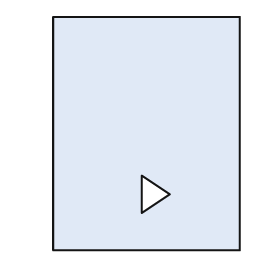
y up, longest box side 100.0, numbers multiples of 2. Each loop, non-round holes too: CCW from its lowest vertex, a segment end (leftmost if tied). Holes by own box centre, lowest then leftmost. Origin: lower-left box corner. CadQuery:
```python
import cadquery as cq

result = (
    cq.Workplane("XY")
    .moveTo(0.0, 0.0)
    .lineTo(80.0, 0.0)
    .lineTo(80.0, 100.0)
    .lineTo(0.0, 100.0)
    .close()
    .moveTo(38.0, 16.0)
    .lineTo(50.0, 24.0)
    .lineTo(38.0, 32.0)
    .close()
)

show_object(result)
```